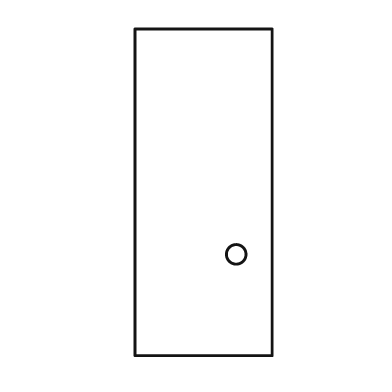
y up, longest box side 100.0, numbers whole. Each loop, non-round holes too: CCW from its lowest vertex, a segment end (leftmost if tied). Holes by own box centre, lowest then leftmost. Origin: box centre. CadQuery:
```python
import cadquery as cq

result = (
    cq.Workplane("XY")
    .moveTo(-21.0, -50.0)
    .lineTo(21.0, -50.0)
    .lineTo(21.0, 50.0)
    .lineTo(-21.0, 50.0)
    .close()
    .moveTo(10.0, -19.0)
    .circle(3.0)
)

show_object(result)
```